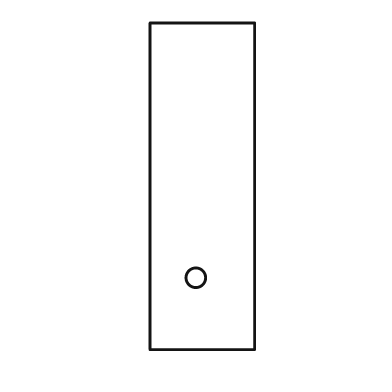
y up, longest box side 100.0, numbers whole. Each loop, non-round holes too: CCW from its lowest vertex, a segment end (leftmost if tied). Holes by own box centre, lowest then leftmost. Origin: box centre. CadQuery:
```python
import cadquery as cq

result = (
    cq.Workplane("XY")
    .moveTo(-16.0, -50.0)
    .lineTo(16.0, -50.0)
    .lineTo(16.0, 50.0)
    .lineTo(-16.0, 50.0)
    .close()
    .moveTo(-2.0, -28.0)
    .circle(3.0)
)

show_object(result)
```